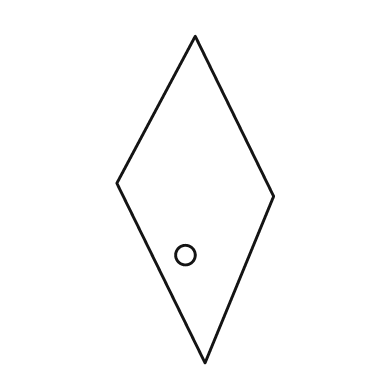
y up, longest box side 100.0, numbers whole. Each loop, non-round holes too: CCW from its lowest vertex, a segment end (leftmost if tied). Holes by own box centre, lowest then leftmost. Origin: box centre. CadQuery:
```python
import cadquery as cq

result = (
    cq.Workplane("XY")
    .moveTo(3.0, -50.0)
    .lineTo(24.0, 1.0)
    .lineTo(0.0, 50.0)
    .lineTo(-24.0, 5.0)
    .close()
    .moveTo(-3.0, -17.0)
    .circle(3.0)
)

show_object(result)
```